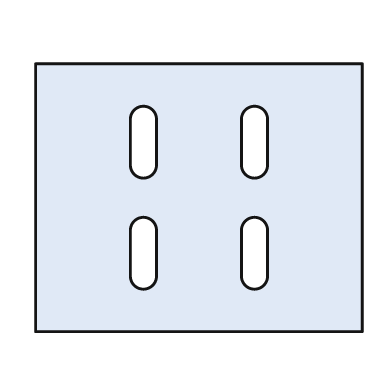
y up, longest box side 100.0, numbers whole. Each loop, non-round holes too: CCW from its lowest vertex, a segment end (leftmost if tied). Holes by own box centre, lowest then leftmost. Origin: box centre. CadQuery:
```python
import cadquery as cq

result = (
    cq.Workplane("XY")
    .moveTo(-50.0, -41.0)
    .lineTo(50.0, -41.0)
    .lineTo(50.0, 41.0)
    .lineTo(-50.0, 41.0)
    .close()
    .moveTo(-21.0, -24.0)
    .threePointArc((-17.0, -28.0), (-13.0, -24.0))
    .lineTo(-13.0, -10.0)
    .threePointArc((-17.0, -6.0), (-21.0, -10.0))
    .close()
    .moveTo(13.0, -24.0)
    .threePointArc((17.0, -28.0), (21.0, -24.0))
    .lineTo(21.0, -10.0)
    .threePointArc((17.0, -6.0), (13.0, -10.0))
    .close()
    .moveTo(-21.0, 10.0)
    .threePointArc((-17.0, 6.0), (-13.0, 10.0))
    .lineTo(-13.0, 24.0)
    .threePointArc((-17.0, 28.0), (-21.0, 24.0))
    .close()
    .moveTo(13.0, 10.0)
    .threePointArc((17.0, 6.0), (21.0, 10.0))
    .lineTo(21.0, 24.0)
    .threePointArc((17.0, 28.0), (13.0, 24.0))
    .close()
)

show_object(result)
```